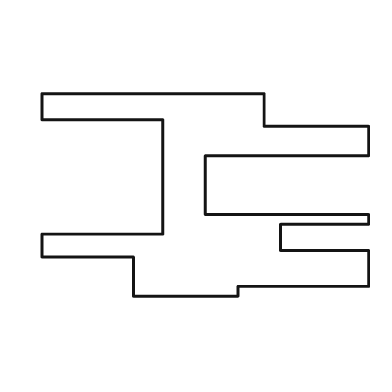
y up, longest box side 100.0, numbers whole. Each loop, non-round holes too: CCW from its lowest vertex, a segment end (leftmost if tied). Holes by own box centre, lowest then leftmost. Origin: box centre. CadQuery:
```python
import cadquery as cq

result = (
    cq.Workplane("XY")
    .moveTo(-22.0, -31.0)
    .lineTo(10.0, -31.0)
    .lineTo(10.0, -28.0)
    .lineTo(50.0, -28.0)
    .lineTo(50.0, -17.0)
    .lineTo(23.0, -17.0)
    .lineTo(23.0, -9.0)
    .lineTo(50.0, -9.0)
    .lineTo(50.0, -6.0)
    .lineTo(0.0, -6.0)
    .lineTo(0.0, 12.0)
    .lineTo(50.0, 12.0)
    .lineTo(50.0, 21.0)
    .lineTo(18.0, 21.0)
    .lineTo(18.0, 31.0)
    .lineTo(-50.0, 31.0)
    .lineTo(-50.0, 23.0)
    .lineTo(-13.0, 23.0)
    .lineTo(-13.0, -12.0)
    .lineTo(-50.0, -12.0)
    .lineTo(-50.0, -19.0)
    .lineTo(-22.0, -19.0)
    .close()
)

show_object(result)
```